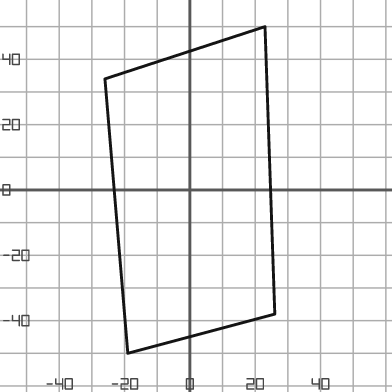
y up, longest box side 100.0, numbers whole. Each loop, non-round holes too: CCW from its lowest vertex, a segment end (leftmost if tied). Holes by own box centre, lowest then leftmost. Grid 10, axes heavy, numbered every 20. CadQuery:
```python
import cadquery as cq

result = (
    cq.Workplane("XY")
    .moveTo(-19.0, -50.0)
    .lineTo(26.0, -38.0)
    .lineTo(23.0, 50.0)
    .lineTo(-26.0, 34.0)
    .close()
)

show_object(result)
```